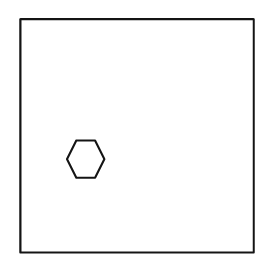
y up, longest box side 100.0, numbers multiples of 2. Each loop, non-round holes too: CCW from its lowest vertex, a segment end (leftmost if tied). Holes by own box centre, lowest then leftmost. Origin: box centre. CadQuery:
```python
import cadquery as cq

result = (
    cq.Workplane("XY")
    .moveTo(-50.0, -50.0)
    .lineTo(50.0, -50.0)
    .lineTo(50.0, 50.0)
    .lineTo(-50.0, 50.0)
    .close()
    .moveTo(-26.0, -18.0)
    .lineTo(-18.0, -18.0)
    .lineTo(-14.0, -10.0)
    .lineTo(-18.0, -2.0)
    .lineTo(-26.0, -2.0)
    .lineTo(-30.0, -10.0)
    .close()
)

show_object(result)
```